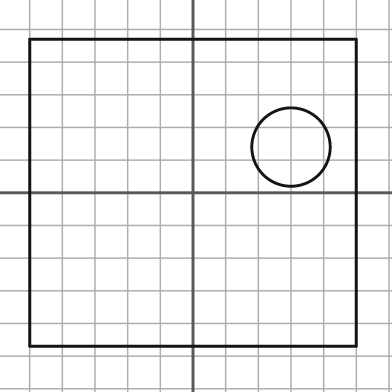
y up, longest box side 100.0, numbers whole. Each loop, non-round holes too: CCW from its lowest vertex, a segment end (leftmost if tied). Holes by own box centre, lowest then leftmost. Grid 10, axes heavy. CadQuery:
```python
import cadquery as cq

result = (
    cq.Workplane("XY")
    .moveTo(-50.0, -47.0)
    .lineTo(50.0, -47.0)
    .lineTo(50.0, 47.0)
    .lineTo(-50.0, 47.0)
    .close()
    .moveTo(30.0, 14.0)
    .circle(12.0)
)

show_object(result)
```